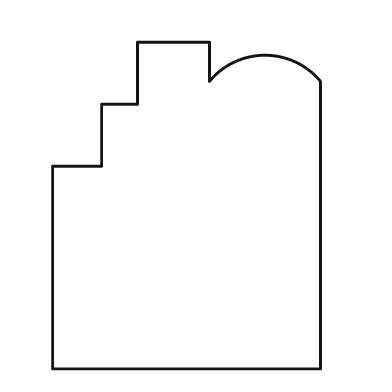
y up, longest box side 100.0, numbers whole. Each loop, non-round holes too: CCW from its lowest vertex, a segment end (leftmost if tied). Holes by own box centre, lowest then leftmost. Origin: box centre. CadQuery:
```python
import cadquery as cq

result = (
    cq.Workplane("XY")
    .moveTo(-41.0, -50.0)
    .lineTo(41.0, -50.0)
    .lineTo(41.0, 38.0)
    .threePointArc((24.0, 46.0), (7.0, 38.0))
    .lineTo(7.0, 50.0)
    .lineTo(-15.0, 50.0)
    .lineTo(-15.0, 31.0)
    .lineTo(-26.0, 31.0)
    .lineTo(-26.0, 12.0)
    .lineTo(-41.0, 12.0)
    .close()
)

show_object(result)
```